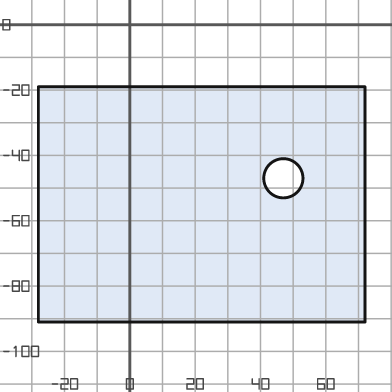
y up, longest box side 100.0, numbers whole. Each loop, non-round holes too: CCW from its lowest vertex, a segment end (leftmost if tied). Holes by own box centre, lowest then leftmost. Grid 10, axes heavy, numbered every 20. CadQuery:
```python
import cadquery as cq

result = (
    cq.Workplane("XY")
    .moveTo(-28.0, -91.0)
    .lineTo(72.0, -91.0)
    .lineTo(72.0, -19.0)
    .lineTo(-28.0, -19.0)
    .close()
    .moveTo(47.0, -47.0)
    .circle(6.0)
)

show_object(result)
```